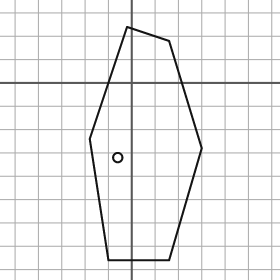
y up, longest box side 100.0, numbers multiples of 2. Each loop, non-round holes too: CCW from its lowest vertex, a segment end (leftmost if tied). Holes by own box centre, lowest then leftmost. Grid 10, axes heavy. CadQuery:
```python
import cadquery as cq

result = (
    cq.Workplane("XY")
    .moveTo(-10.0, -76.0)
    .lineTo(16.0, -76.0)
    .lineTo(30.0, -28.0)
    .lineTo(16.0, 18.0)
    .lineTo(-2.0, 24.0)
    .lineTo(-18.0, -24.0)
    .close()
    .moveTo(-6.0, -32.0)
    .circle(2.0)
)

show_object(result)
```